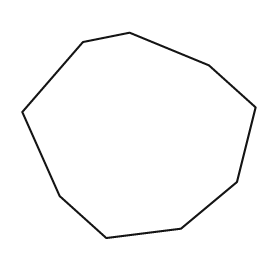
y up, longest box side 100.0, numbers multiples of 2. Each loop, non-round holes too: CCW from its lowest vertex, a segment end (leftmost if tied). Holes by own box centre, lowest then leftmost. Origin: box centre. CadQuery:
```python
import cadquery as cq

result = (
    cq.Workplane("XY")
    .moveTo(-14.0, -44.0)
    .lineTo(18.0, -40.0)
    .lineTo(42.0, -20.0)
    .lineTo(50.0, 12.0)
    .lineTo(30.0, 30.0)
    .lineTo(-4.0, 44.0)
    .lineTo(-24.0, 40.0)
    .lineTo(-50.0, 10.0)
    .lineTo(-34.0, -26.0)
    .close()
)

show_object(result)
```